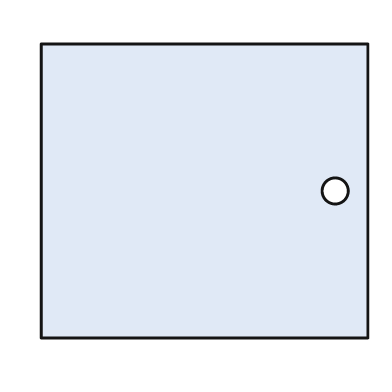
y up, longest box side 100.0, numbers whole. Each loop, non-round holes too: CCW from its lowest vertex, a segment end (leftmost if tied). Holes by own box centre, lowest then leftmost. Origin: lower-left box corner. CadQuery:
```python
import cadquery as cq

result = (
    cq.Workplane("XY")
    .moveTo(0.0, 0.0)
    .lineTo(100.0, 0.0)
    .lineTo(100.0, 90.0)
    .lineTo(0.0, 90.0)
    .close()
    .moveTo(90.0, 45.0)
    .circle(4.0)
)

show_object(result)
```